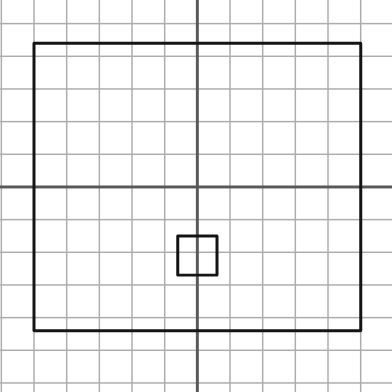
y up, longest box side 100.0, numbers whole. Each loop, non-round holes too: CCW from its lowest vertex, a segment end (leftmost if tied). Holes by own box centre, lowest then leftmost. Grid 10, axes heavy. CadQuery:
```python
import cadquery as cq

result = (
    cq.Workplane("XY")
    .moveTo(-50.0, -44.0)
    .lineTo(50.0, -44.0)
    .lineTo(50.0, 44.0)
    .lineTo(-50.0, 44.0)
    .close()
    .moveTo(-6.0, -27.0)
    .lineTo(6.0, -27.0)
    .lineTo(6.0, -15.0)
    .lineTo(-6.0, -15.0)
    .close()
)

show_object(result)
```